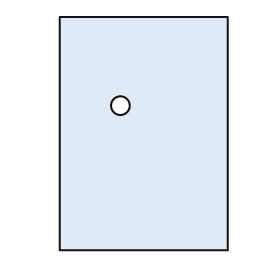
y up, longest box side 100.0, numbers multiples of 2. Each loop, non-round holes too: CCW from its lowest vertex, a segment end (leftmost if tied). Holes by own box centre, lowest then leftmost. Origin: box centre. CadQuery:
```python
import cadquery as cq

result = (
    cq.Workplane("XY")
    .moveTo(-36.0, -50.0)
    .lineTo(36.0, -50.0)
    .lineTo(36.0, 50.0)
    .lineTo(-36.0, 50.0)
    .close()
    .moveTo(-10.0, 12.0)
    .circle(4.0)
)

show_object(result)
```